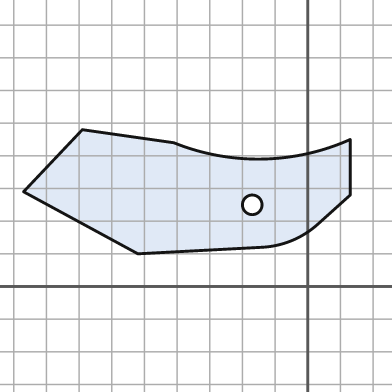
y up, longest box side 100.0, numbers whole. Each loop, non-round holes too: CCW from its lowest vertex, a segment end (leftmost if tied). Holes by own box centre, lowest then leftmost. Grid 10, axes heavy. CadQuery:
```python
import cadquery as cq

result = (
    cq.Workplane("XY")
    .moveTo(-52.0, 10.0)
    .lineTo(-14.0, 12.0)
    .threePointArc((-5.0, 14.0), (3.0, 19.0))
    .lineTo(13.0, 28.0)
    .lineTo(13.0, 45.0)
    .threePointArc((-14.0, 39.0), (-41.0, 44.0))
    .lineTo(-69.0, 48.0)
    .lineTo(-87.0, 29.0)
    .close()
    .moveTo(-17.0, 25.0)
    .circle(3.0)
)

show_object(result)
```